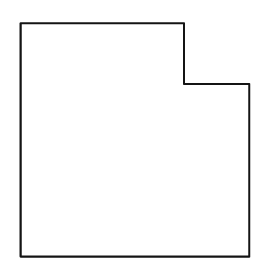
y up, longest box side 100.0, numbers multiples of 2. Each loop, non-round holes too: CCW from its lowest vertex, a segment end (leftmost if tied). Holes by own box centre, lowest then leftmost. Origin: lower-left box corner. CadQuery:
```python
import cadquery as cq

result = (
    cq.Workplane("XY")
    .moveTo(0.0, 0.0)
    .lineTo(98.0, 0.0)
    .lineTo(98.0, 74.0)
    .lineTo(70.0, 74.0)
    .lineTo(70.0, 100.0)
    .lineTo(0.0, 100.0)
    .close()
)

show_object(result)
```